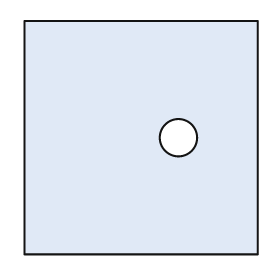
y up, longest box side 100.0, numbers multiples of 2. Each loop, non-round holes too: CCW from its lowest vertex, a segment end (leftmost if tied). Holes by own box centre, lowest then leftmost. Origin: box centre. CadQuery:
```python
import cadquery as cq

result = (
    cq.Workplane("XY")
    .moveTo(-50.0, -50.0)
    .lineTo(50.0, -50.0)
    .lineTo(50.0, 50.0)
    .lineTo(-50.0, 50.0)
    .close()
    .moveTo(16.0, 0.0)
    .circle(8.0)
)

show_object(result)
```